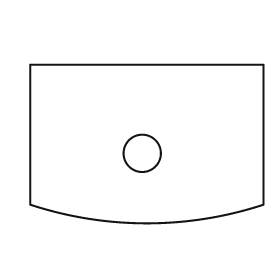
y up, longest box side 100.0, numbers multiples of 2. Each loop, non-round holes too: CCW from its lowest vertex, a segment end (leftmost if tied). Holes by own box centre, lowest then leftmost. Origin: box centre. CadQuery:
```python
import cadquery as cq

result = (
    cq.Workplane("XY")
    .moveTo(-50.0, -26.0)
    .threePointArc((0.0, -34.0), (50.0, -26.0))
    .lineTo(50.0, 34.0)
    .lineTo(-50.0, 34.0)
    .close()
    .moveTo(-2.0, -4.0)
    .circle(8.0)
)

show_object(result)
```